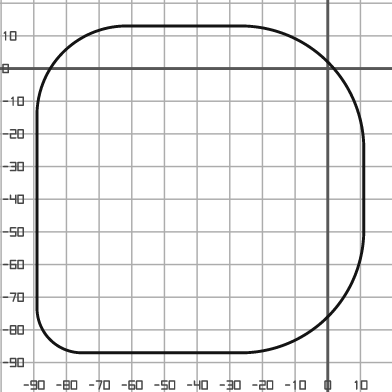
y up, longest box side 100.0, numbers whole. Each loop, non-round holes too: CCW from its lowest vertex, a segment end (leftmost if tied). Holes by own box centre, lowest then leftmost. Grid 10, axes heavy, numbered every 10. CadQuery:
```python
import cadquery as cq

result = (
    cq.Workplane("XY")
    .moveTo(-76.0, -87.0)
    .lineTo(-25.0, -87.0)
    .threePointArc((0.0, -76.0), (11.0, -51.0))
    .lineTo(11.0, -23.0)
    .threePointArc((0.0, 2.0), (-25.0, 13.0))
    .lineTo(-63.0, 13.0)
    .threePointArc((-81.0, 5.0), (-89.0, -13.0))
    .lineTo(-89.0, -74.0)
    .threePointArc((-85.0, -83.0), (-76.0, -87.0))
    .close()
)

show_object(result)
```